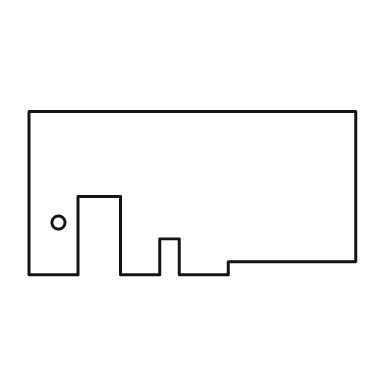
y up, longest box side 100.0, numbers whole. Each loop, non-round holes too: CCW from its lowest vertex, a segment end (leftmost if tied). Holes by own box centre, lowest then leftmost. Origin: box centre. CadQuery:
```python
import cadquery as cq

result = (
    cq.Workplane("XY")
    .moveTo(-50.0, -25.0)
    .lineTo(-35.0, -25.0)
    .lineTo(-35.0, -1.0)
    .lineTo(-22.0, -1.0)
    .lineTo(-22.0, -25.0)
    .lineTo(-10.0, -25.0)
    .lineTo(-10.0, -14.0)
    .lineTo(-4.0, -14.0)
    .lineTo(-4.0, -25.0)
    .lineTo(11.0, -25.0)
    .lineTo(11.0, -21.0)
    .lineTo(50.0, -21.0)
    .lineTo(50.0, 25.0)
    .lineTo(-50.0, 25.0)
    .close()
    .moveTo(-41.0, -9.0)
    .circle(2.0)
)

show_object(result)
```